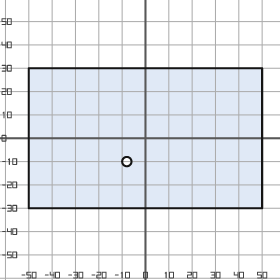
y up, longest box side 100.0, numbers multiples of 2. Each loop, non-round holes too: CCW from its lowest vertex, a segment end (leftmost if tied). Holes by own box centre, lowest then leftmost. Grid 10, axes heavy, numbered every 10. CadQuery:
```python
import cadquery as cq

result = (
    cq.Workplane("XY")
    .moveTo(-50.0, -30.0)
    .lineTo(50.0, -30.0)
    .lineTo(50.0, 30.0)
    .lineTo(-50.0, 30.0)
    .close()
    .moveTo(-8.0, -10.0)
    .circle(2.0)
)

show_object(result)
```